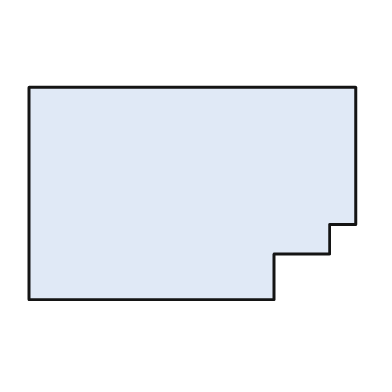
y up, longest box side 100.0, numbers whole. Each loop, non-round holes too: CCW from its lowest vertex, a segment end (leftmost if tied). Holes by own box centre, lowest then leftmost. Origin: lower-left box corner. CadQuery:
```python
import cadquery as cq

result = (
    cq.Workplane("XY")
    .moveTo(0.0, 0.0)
    .lineTo(75.0, 0.0)
    .lineTo(75.0, 14.0)
    .lineTo(92.0, 14.0)
    .lineTo(92.0, 23.0)
    .lineTo(100.0, 23.0)
    .lineTo(100.0, 65.0)
    .lineTo(0.0, 65.0)
    .close()
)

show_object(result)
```